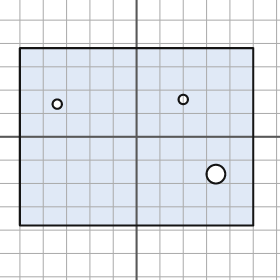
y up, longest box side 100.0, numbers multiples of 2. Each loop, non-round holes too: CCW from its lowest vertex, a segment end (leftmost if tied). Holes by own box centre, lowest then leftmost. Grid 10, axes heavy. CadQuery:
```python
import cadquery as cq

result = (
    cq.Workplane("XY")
    .moveTo(-50.0, -38.0)
    .lineTo(50.0, -38.0)
    .lineTo(50.0, 38.0)
    .lineTo(-50.0, 38.0)
    .close()
    .moveTo(34.0, -16.0)
    .circle(4.0)
    .moveTo(-34.0, 14.0)
    .circle(2.0)
    .moveTo(20.0, 16.0)
    .circle(2.0)
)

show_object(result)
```